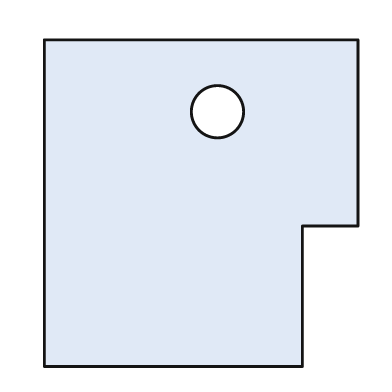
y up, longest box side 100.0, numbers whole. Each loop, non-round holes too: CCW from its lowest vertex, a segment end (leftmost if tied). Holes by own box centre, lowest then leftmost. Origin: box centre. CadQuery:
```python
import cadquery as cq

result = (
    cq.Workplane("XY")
    .moveTo(-48.0, -50.0)
    .lineTo(31.0, -50.0)
    .lineTo(31.0, -7.0)
    .lineTo(48.0, -7.0)
    .lineTo(48.0, 50.0)
    .lineTo(-48.0, 50.0)
    .close()
    .moveTo(5.0, 28.0)
    .circle(8.0)
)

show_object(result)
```